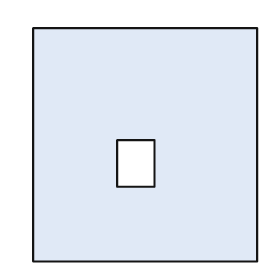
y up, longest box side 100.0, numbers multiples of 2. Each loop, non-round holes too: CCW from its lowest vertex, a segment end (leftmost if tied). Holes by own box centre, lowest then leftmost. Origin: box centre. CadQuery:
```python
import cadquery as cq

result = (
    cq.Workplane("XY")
    .moveTo(-48.0, -50.0)
    .lineTo(48.0, -50.0)
    .lineTo(48.0, 50.0)
    .lineTo(-48.0, 50.0)
    .close()
    .moveTo(-12.0, -18.0)
    .lineTo(4.0, -18.0)
    .lineTo(4.0, 2.0)
    .lineTo(-12.0, 2.0)
    .close()
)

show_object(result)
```